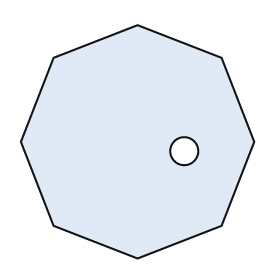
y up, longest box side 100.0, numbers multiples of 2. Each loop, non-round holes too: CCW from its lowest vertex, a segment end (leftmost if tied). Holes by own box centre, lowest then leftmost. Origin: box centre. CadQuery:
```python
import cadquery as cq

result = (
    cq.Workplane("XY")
    .moveTo(0.0, -50.0)
    .lineTo(36.0, -36.0)
    .lineTo(50.0, 0.0)
    .lineTo(36.0, 36.0)
    .lineTo(0.0, 50.0)
    .lineTo(-36.0, 36.0)
    .lineTo(-50.0, 0.0)
    .lineTo(-36.0, -36.0)
    .close()
    .moveTo(20.0, -4.0)
    .circle(6.0)
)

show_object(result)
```